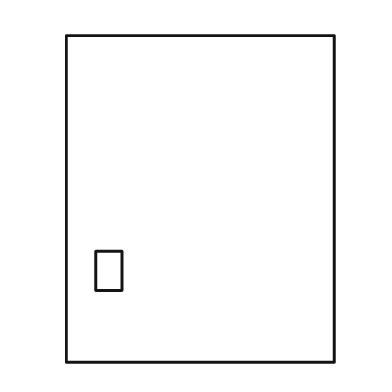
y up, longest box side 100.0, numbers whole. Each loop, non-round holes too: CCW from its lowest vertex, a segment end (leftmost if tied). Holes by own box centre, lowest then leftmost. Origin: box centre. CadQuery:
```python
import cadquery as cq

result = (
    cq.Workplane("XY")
    .moveTo(-41.0, -50.0)
    .lineTo(41.0, -50.0)
    .lineTo(41.0, 50.0)
    .lineTo(-41.0, 50.0)
    .close()
    .moveTo(-32.0, -28.0)
    .lineTo(-24.0, -28.0)
    .lineTo(-24.0, -16.0)
    .lineTo(-32.0, -16.0)
    .close()
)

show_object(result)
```